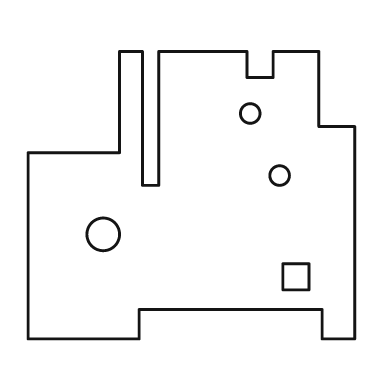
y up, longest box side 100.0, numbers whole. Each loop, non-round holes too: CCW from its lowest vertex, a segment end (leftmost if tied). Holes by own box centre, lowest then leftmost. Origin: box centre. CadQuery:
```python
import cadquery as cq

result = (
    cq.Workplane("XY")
    .moveTo(-50.0, -44.0)
    .lineTo(-16.0, -44.0)
    .lineTo(-16.0, -35.0)
    .lineTo(40.0, -35.0)
    .lineTo(40.0, -44.0)
    .lineTo(50.0, -44.0)
    .lineTo(50.0, 21.0)
    .lineTo(39.0, 21.0)
    .lineTo(39.0, 44.0)
    .lineTo(25.0, 44.0)
    .lineTo(25.0, 36.0)
    .lineTo(17.0, 36.0)
    .lineTo(17.0, 44.0)
    .lineTo(-10.0, 44.0)
    .lineTo(-10.0, 3.0)
    .lineTo(-15.0, 3.0)
    .lineTo(-15.0, 44.0)
    .lineTo(-22.0, 44.0)
    .lineTo(-22.0, 13.0)
    .lineTo(-50.0, 13.0)
    .close()
    .moveTo(28.0, -29.0)
    .lineTo(36.0, -29.0)
    .lineTo(36.0, -21.0)
    .lineTo(28.0, -21.0)
    .close()
    .moveTo(-27.0, -12.0)
    .circle(5.0)
    .moveTo(27.0, 6.0)
    .circle(3.0)
    .moveTo(18.0, 25.0)
    .circle(3.0)
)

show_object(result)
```